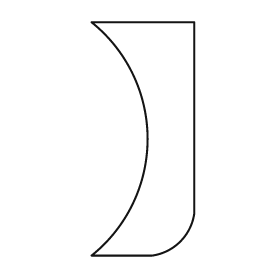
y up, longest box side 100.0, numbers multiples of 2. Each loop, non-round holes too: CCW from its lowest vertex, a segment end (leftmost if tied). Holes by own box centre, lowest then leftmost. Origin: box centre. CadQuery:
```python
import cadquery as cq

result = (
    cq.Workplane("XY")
    .moveTo(-22.0, -50.0)
    .lineTo(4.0, -50.0)
    .threePointArc((16.0, -44.0), (22.0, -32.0))
    .lineTo(22.0, 50.0)
    .lineTo(-22.0, 50.0)
    .threePointArc((2.0, 0.0), (-22.0, -50.0))
    .close()
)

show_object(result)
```